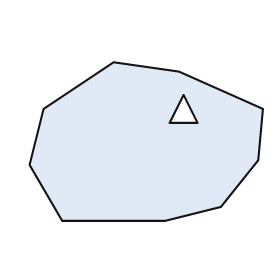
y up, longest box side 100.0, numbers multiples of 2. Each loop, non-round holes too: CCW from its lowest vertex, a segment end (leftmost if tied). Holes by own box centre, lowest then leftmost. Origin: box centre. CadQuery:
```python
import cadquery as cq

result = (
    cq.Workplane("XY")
    .moveTo(-36.0, -34.0)
    .lineTo(8.0, -34.0)
    .lineTo(32.0, -28.0)
    .lineTo(48.0, -8.0)
    .lineTo(50.0, 14.0)
    .lineTo(14.0, 30.0)
    .lineTo(-14.0, 34.0)
    .lineTo(-44.0, 14.0)
    .lineTo(-50.0, -10.0)
    .close()
    .moveTo(10.0, 8.0)
    .lineTo(22.0, 8.0)
    .lineTo(16.0, 20.0)
    .close()
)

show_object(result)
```